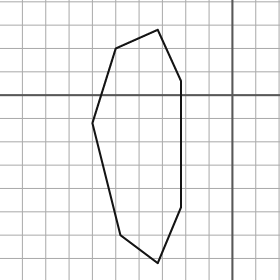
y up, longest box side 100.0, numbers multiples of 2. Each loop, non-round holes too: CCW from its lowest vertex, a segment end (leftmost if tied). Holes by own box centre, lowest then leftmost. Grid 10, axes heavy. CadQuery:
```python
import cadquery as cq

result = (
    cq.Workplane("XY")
    .moveTo(-32.0, -72.0)
    .lineTo(-22.0, -48.0)
    .lineTo(-22.0, 6.0)
    .lineTo(-32.0, 28.0)
    .lineTo(-50.0, 20.0)
    .lineTo(-60.0, -12.0)
    .lineTo(-48.0, -60.0)
    .close()
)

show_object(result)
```